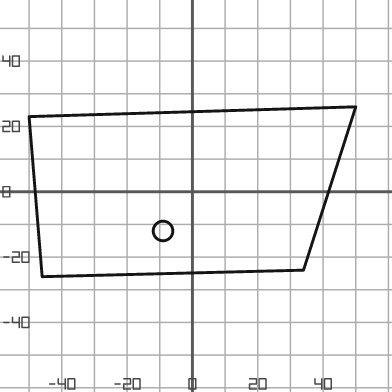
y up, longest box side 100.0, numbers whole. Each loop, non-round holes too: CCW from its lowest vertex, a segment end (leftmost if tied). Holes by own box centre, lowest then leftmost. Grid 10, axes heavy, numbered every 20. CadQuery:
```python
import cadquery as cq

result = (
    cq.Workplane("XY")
    .moveTo(-46.0, -26.0)
    .lineTo(34.0, -24.0)
    .lineTo(50.0, 26.0)
    .lineTo(-50.0, 23.0)
    .close()
    .moveTo(-9.0, -12.0)
    .circle(3.0)
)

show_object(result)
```